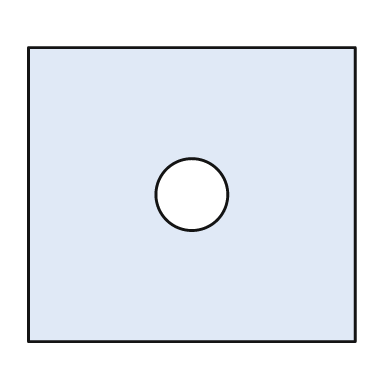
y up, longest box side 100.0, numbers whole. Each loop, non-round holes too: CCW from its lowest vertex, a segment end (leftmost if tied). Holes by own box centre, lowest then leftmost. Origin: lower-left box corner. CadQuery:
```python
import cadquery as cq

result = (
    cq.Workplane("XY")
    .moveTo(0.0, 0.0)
    .lineTo(100.0, 0.0)
    .lineTo(100.0, 90.0)
    .lineTo(0.0, 90.0)
    .close()
    .moveTo(50.0, 45.0)
    .circle(11.0)
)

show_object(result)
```